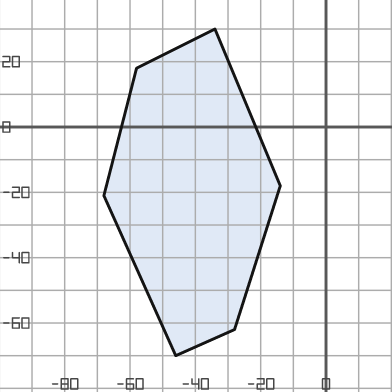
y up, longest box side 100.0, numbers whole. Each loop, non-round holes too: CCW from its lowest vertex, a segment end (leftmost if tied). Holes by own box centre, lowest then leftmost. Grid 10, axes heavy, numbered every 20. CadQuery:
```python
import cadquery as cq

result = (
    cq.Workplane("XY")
    .moveTo(-46.0, -70.0)
    .lineTo(-28.0, -62.0)
    .lineTo(-14.0, -18.0)
    .lineTo(-34.0, 30.0)
    .lineTo(-58.0, 18.0)
    .lineTo(-68.0, -21.0)
    .close()
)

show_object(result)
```